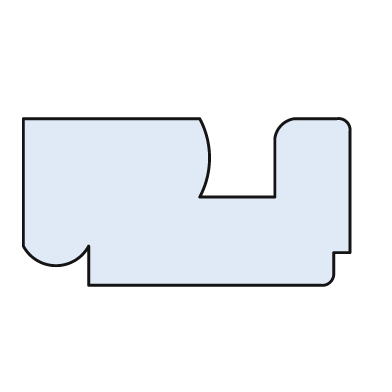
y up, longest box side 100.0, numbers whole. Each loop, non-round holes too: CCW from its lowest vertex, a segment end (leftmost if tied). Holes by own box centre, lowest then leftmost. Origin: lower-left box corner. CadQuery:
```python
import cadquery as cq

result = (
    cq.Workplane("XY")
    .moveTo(20.0, 0.0)
    .lineTo(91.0, 0.0)
    .threePointArc((94.0, 1.0), (95.0, 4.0))
    .lineTo(95.0, 10.0)
    .lineTo(100.0, 10.0)
    .lineTo(100.0, 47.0)
    .threePointArc((99.0, 50.0), (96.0, 51.0))
    .lineTo(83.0, 51.0)
    .threePointArc((79.0, 49.0), (77.0, 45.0))
    .lineTo(77.0, 27.0)
    .lineTo(54.0, 27.0)
    .threePointArc((57.0, 39.0), (54.0, 51.0))
    .lineTo(0.0, 51.0)
    .lineTo(0.0, 12.0)
    .threePointArc((10.0, 6.0), (20.0, 12.0))
    .close()
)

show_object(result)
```